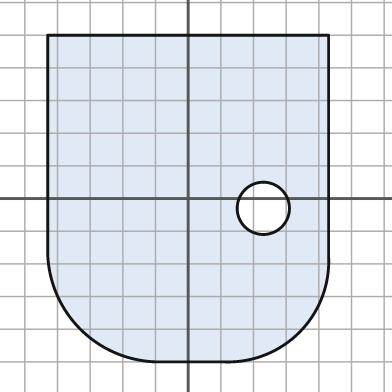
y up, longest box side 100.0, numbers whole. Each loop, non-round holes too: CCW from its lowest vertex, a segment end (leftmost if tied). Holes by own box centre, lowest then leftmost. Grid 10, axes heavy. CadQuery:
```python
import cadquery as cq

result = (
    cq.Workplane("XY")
    .moveTo(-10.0, -50.0)
    .lineTo(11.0, -50.0)
    .threePointArc((34.0, -41.0), (43.0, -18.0))
    .lineTo(43.0, 50.0)
    .lineTo(-43.0, 50.0)
    .lineTo(-43.0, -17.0)
    .threePointArc((-33.0, -40.0), (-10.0, -50.0))
    .close()
    .moveTo(23.0, -3.0)
    .circle(8.0)
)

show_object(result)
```